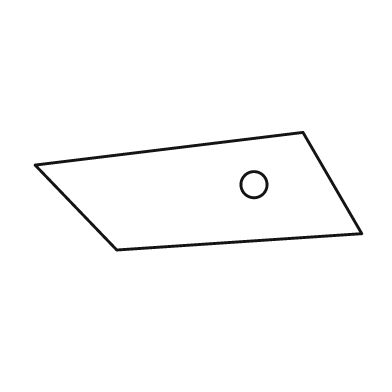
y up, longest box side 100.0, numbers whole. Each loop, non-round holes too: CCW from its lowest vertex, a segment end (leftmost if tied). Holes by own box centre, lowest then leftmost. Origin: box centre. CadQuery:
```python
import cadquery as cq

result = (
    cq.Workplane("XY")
    .moveTo(-25.0, -18.0)
    .lineTo(50.0, -13.0)
    .lineTo(32.0, 18.0)
    .lineTo(-50.0, 8.0)
    .close()
    .moveTo(17.0, 2.0)
    .circle(4.0)
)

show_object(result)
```